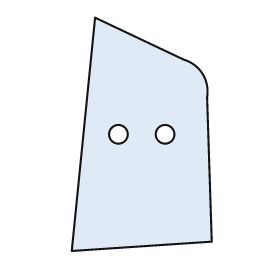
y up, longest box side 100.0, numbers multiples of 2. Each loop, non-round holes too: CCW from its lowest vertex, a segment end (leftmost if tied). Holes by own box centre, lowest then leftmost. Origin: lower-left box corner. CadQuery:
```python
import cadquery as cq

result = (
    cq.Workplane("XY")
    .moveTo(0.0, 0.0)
    .lineTo(60.0, 4.0)
    .lineTo(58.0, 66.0)
    .threePointArc((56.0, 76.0), (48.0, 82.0))
    .lineTo(10.0, 100.0)
    .close()
    .moveTo(20.0, 50.0)
    .circle(4.0)
    .moveTo(40.0, 50.0)
    .circle(4.0)
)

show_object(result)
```